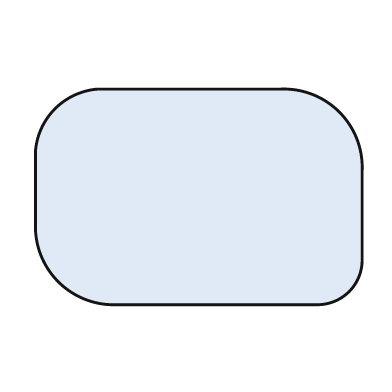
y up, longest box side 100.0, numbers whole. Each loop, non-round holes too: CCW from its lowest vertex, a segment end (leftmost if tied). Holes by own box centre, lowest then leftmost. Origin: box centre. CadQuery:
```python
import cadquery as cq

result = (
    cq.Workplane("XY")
    .moveTo(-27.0, -33.0)
    .lineTo(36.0, -33.0)
    .threePointArc((46.0, -29.0), (50.0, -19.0))
    .lineTo(50.0, 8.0)
    .threePointArc((43.0, 26.0), (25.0, 33.0))
    .lineTo(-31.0, 33.0)
    .threePointArc((-44.0, 27.0), (-50.0, 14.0))
    .lineTo(-50.0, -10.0)
    .threePointArc((-43.0, -26.0), (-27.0, -33.0))
    .close()
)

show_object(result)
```